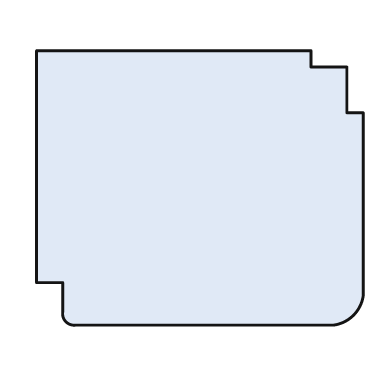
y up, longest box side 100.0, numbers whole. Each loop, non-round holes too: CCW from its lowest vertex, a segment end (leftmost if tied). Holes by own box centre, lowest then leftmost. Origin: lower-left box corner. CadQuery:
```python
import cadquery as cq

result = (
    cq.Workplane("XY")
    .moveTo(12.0, 0.0)
    .lineTo(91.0, 0.0)
    .threePointArc((97.0, 3.0), (100.0, 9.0))
    .lineTo(100.0, 65.0)
    .lineTo(95.0, 65.0)
    .lineTo(95.0, 79.0)
    .lineTo(84.0, 79.0)
    .lineTo(84.0, 84.0)
    .lineTo(0.0, 84.0)
    .lineTo(0.0, 13.0)
    .lineTo(8.0, 13.0)
    .lineTo(8.0, 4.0)
    .threePointArc((9.0, 1.0), (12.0, 0.0))
    .close()
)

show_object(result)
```